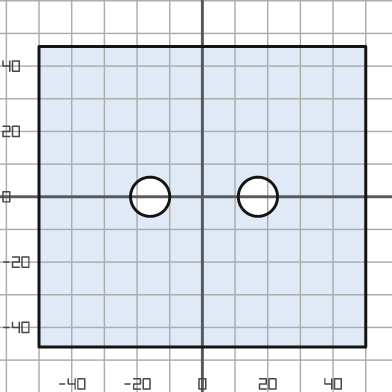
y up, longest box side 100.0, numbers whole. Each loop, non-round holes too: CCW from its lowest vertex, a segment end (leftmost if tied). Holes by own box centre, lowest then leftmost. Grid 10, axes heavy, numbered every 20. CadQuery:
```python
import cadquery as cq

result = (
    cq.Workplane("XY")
    .moveTo(-50.0, -46.0)
    .lineTo(50.0, -46.0)
    .lineTo(50.0, 46.0)
    .lineTo(-50.0, 46.0)
    .close()
    .moveTo(-16.0, 0.0)
    .circle(6.0)
    .moveTo(17.0, 0.0)
    .circle(6.0)
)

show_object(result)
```